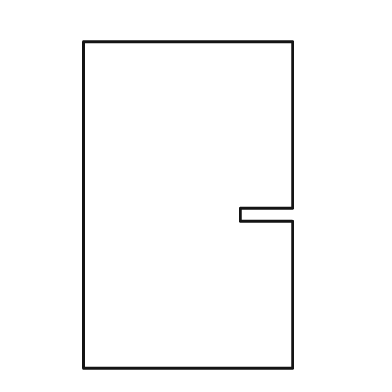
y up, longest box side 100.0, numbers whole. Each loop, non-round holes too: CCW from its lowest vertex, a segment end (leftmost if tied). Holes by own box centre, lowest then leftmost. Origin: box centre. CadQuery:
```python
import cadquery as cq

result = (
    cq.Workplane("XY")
    .moveTo(-32.0, -50.0)
    .lineTo(32.0, -50.0)
    .lineTo(32.0, -5.0)
    .lineTo(16.0, -5.0)
    .lineTo(16.0, -1.0)
    .lineTo(32.0, -1.0)
    .lineTo(32.0, 50.0)
    .lineTo(-32.0, 50.0)
    .close()
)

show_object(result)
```